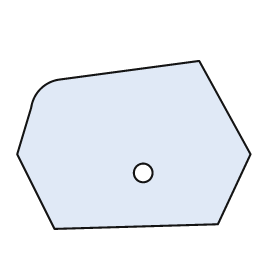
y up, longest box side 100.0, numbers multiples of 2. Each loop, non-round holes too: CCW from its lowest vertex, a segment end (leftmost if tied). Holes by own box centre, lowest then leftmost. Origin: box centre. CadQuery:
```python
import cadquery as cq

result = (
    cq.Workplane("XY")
    .moveTo(-34.0, -36.0)
    .lineTo(36.0, -34.0)
    .lineTo(50.0, -4.0)
    .lineTo(28.0, 36.0)
    .lineTo(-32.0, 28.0)
    .threePointArc((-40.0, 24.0), (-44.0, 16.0))
    .lineTo(-50.0, -4.0)
    .close()
    .moveTo(4.0, -12.0)
    .circle(4.0)
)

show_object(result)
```